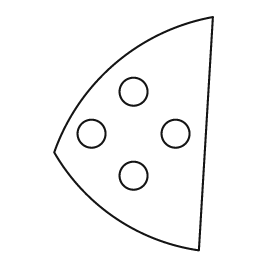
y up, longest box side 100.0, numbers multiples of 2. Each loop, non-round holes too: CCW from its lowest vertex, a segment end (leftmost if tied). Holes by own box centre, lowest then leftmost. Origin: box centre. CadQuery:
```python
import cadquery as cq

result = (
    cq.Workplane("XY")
    .moveTo(28.0, -50.0)
    .lineTo(34.0, 50.0)
    .threePointArc((-8.0, 30.0), (-34.0, -8.0))
    .threePointArc((-8.0, -36.0), (28.0, -50.0))
    .close()
    .moveTo(0.0, -18.0)
    .circle(6.0)
    .moveTo(-18.0, 0.0)
    .circle(6.0)
    .moveTo(18.0, 0.0)
    .circle(6.0)
    .moveTo(0.0, 18.0)
    .circle(6.0)
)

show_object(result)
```